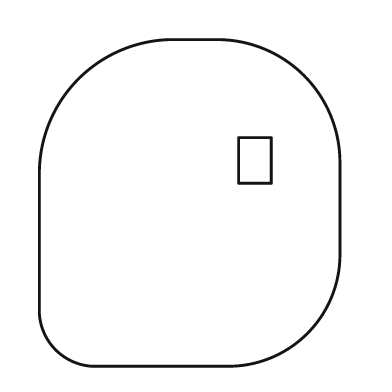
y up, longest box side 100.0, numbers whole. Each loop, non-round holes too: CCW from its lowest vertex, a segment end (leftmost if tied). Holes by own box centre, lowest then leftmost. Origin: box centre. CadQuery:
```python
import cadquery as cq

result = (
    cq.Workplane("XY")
    .moveTo(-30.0, -50.0)
    .lineTo(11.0, -50.0)
    .threePointArc((36.0, -40.0), (46.0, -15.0))
    .lineTo(46.0, 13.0)
    .threePointArc((35.0, 39.0), (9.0, 50.0))
    .lineTo(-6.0, 50.0)
    .threePointArc((-34.0, 38.0), (-46.0, 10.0))
    .lineTo(-46.0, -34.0)
    .threePointArc((-41.0, -45.0), (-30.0, -50.0))
    .close()
    .moveTo(15.0, 6.0)
    .lineTo(25.0, 6.0)
    .lineTo(25.0, 20.0)
    .lineTo(15.0, 20.0)
    .close()
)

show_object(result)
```